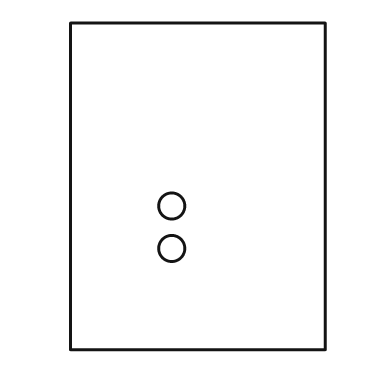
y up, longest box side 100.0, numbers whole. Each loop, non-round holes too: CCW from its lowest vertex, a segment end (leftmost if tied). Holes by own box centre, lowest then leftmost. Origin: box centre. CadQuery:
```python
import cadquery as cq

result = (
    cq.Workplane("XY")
    .moveTo(-39.0, -50.0)
    .lineTo(39.0, -50.0)
    .lineTo(39.0, 50.0)
    .lineTo(-39.0, 50.0)
    .close()
    .moveTo(-8.0, -19.0)
    .circle(4.0)
    .moveTo(-8.0, -6.0)
    .circle(4.0)
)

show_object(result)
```